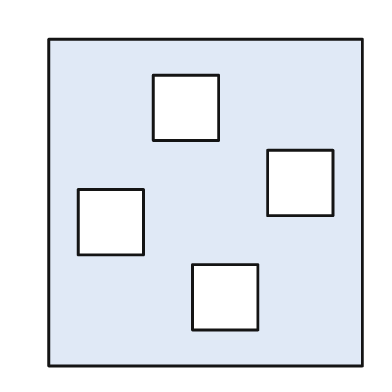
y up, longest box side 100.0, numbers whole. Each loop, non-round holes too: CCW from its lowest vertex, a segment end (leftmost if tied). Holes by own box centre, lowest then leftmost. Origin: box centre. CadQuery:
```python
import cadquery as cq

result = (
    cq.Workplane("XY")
    .moveTo(-48.0, -50.0)
    .lineTo(48.0, -50.0)
    .lineTo(48.0, 50.0)
    .lineTo(-48.0, 50.0)
    .close()
    .moveTo(-4.0, -39.0)
    .lineTo(16.0, -39.0)
    .lineTo(16.0, -19.0)
    .lineTo(-4.0, -19.0)
    .close()
    .moveTo(-39.0, -16.0)
    .lineTo(-19.0, -16.0)
    .lineTo(-19.0, 4.0)
    .lineTo(-39.0, 4.0)
    .close()
    .moveTo(19.0, -4.0)
    .lineTo(39.0, -4.0)
    .lineTo(39.0, 16.0)
    .lineTo(19.0, 16.0)
    .close()
    .moveTo(-16.0, 19.0)
    .lineTo(4.0, 19.0)
    .lineTo(4.0, 39.0)
    .lineTo(-16.0, 39.0)
    .close()
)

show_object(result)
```